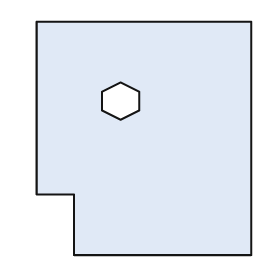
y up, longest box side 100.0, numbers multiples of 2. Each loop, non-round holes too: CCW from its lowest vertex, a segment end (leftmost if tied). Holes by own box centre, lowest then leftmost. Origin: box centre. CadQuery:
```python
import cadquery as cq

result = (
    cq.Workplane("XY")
    .moveTo(-30.0, -50.0)
    .lineTo(46.0, -50.0)
    .lineTo(46.0, 50.0)
    .lineTo(-46.0, 50.0)
    .lineTo(-46.0, -24.0)
    .lineTo(-30.0, -24.0)
    .close()
    .moveTo(-10.0, 8.0)
    .lineTo(-2.0, 12.0)
    .lineTo(-2.0, 20.0)
    .lineTo(-10.0, 24.0)
    .lineTo(-18.0, 20.0)
    .lineTo(-18.0, 12.0)
    .close()
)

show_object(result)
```